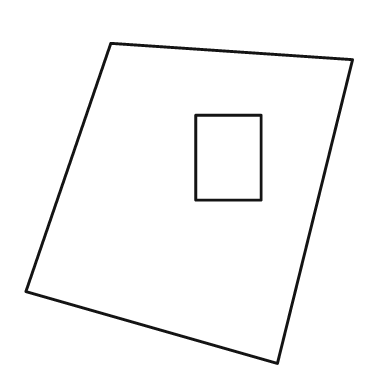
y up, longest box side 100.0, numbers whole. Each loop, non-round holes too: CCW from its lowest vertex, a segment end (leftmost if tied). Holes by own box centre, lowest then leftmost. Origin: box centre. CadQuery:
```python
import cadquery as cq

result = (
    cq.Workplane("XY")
    .moveTo(27.0, -49.0)
    .lineTo(50.0, 44.0)
    .lineTo(-24.0, 49.0)
    .lineTo(-50.0, -27.0)
    .close()
    .moveTo(2.0, 1.0)
    .lineTo(22.0, 1.0)
    .lineTo(22.0, 27.0)
    .lineTo(2.0, 27.0)
    .close()
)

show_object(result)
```